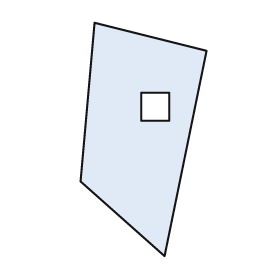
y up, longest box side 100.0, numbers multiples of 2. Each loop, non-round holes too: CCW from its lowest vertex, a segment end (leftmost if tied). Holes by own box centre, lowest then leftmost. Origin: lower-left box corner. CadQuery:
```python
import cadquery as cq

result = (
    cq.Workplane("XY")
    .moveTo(36.0, 0.0)
    .lineTo(54.0, 88.0)
    .lineTo(6.0, 100.0)
    .lineTo(0.0, 32.0)
    .close()
    .moveTo(26.0, 58.0)
    .lineTo(38.0, 58.0)
    .lineTo(38.0, 70.0)
    .lineTo(26.0, 70.0)
    .close()
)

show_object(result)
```